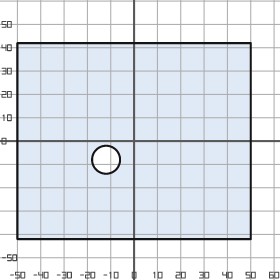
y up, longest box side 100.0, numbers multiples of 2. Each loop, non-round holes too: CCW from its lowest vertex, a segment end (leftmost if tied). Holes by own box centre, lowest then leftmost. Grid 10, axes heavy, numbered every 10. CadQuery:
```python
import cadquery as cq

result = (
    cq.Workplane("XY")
    .moveTo(-50.0, -42.0)
    .lineTo(50.0, -42.0)
    .lineTo(50.0, 42.0)
    .lineTo(-50.0, 42.0)
    .close()
    .moveTo(-12.0, -8.0)
    .circle(6.0)
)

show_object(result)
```